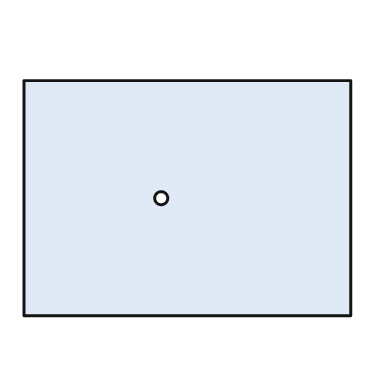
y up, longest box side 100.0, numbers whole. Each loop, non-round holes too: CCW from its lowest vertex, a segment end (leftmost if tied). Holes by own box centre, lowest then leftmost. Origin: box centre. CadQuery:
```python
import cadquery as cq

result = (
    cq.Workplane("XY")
    .moveTo(-50.0, -36.0)
    .lineTo(50.0, -36.0)
    .lineTo(50.0, 36.0)
    .lineTo(-50.0, 36.0)
    .close()
    .moveTo(-8.0, 0.0)
    .circle(2.0)
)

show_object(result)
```